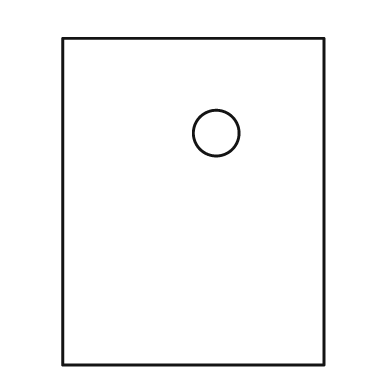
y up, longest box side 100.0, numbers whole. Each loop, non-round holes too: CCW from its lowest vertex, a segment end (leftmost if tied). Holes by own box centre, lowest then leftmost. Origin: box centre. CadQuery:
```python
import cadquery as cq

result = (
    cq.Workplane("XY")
    .moveTo(-40.0, -50.0)
    .lineTo(40.0, -50.0)
    .lineTo(40.0, 50.0)
    .lineTo(-40.0, 50.0)
    .close()
    .moveTo(7.0, 21.0)
    .circle(7.0)
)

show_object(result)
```